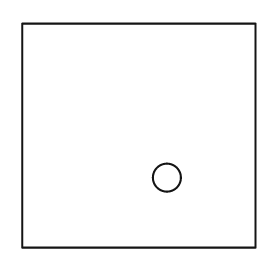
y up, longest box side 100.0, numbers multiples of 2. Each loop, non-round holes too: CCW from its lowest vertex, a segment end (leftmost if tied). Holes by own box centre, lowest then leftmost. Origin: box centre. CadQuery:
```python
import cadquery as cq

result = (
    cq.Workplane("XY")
    .moveTo(-50.0, -48.0)
    .lineTo(50.0, -48.0)
    .lineTo(50.0, 48.0)
    .lineTo(-50.0, 48.0)
    .close()
    .moveTo(12.0, -18.0)
    .circle(6.0)
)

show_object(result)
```